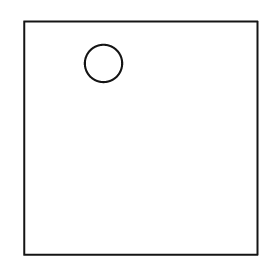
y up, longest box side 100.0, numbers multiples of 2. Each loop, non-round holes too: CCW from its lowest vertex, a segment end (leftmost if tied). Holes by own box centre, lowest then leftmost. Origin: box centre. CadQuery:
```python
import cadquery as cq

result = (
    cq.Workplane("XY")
    .moveTo(-50.0, -50.0)
    .lineTo(50.0, -50.0)
    .lineTo(50.0, 50.0)
    .lineTo(-50.0, 50.0)
    .close()
    .moveTo(-16.0, 32.0)
    .circle(8.0)
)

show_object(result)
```